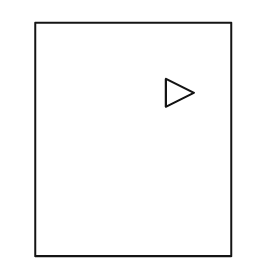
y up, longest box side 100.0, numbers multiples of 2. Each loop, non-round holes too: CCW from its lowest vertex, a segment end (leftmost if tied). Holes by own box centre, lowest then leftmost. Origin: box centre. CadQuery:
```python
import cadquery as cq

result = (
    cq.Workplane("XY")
    .moveTo(-42.0, -50.0)
    .lineTo(42.0, -50.0)
    .lineTo(42.0, 50.0)
    .lineTo(-42.0, 50.0)
    .close()
    .moveTo(14.0, 14.0)
    .lineTo(26.0, 20.0)
    .lineTo(14.0, 26.0)
    .close()
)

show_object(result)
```